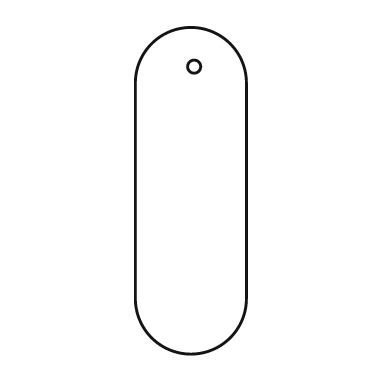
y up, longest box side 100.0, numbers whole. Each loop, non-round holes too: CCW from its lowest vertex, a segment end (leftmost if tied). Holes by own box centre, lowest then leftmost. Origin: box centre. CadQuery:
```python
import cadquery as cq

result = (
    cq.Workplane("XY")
    .moveTo(-17.0, -33.0)
    .threePointArc((0.0, -50.0), (17.0, -33.0))
    .lineTo(17.0, 33.0)
    .threePointArc((0.0, 50.0), (-17.0, 33.0))
    .close()
    .moveTo(1.0, 38.0)
    .circle(2.0)
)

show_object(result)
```